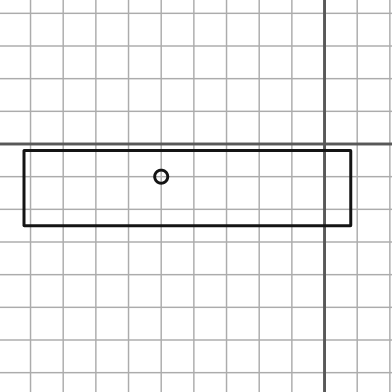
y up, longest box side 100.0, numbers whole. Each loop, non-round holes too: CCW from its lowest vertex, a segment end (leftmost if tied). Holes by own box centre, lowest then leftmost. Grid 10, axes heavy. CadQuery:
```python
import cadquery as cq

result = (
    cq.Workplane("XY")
    .moveTo(-92.0, -25.0)
    .lineTo(8.0, -25.0)
    .lineTo(8.0, -2.0)
    .lineTo(-92.0, -2.0)
    .close()
    .moveTo(-50.0, -10.0)
    .circle(2.0)
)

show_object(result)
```